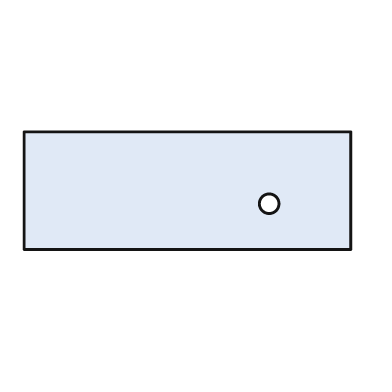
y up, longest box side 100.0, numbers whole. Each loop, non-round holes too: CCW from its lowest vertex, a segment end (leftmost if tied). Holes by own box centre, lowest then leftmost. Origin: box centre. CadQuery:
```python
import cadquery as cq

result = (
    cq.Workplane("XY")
    .moveTo(-50.0, -18.0)
    .lineTo(50.0, -18.0)
    .lineTo(50.0, 18.0)
    .lineTo(-50.0, 18.0)
    .close()
    .moveTo(25.0, -4.0)
    .circle(3.0)
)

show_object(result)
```